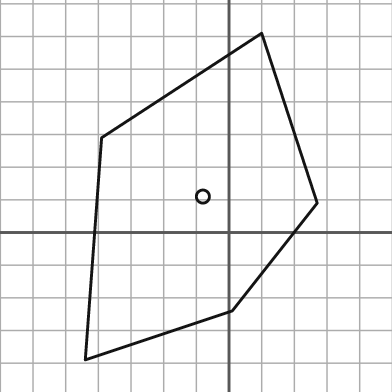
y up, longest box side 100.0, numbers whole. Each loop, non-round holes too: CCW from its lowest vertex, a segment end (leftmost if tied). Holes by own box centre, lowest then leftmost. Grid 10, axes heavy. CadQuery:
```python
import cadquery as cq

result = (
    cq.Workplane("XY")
    .moveTo(-44.0, -39.0)
    .lineTo(1.0, -24.0)
    .lineTo(27.0, 9.0)
    .lineTo(10.0, 61.0)
    .lineTo(-39.0, 29.0)
    .close()
    .moveTo(-8.0, 11.0)
    .circle(2.0)
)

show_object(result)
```